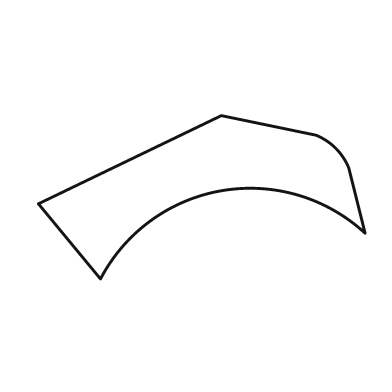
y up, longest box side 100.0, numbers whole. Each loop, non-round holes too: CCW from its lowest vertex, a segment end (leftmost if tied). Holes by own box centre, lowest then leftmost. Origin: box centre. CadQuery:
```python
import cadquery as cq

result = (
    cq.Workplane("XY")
    .moveTo(-31.0, -25.0)
    .threePointArc((6.0, 2.0), (50.0, -11.0))
    .lineTo(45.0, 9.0)
    .threePointArc((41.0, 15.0), (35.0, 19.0))
    .lineTo(6.0, 25.0)
    .lineTo(-50.0, -2.0)
    .close()
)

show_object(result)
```